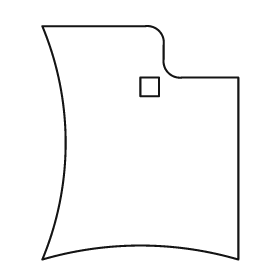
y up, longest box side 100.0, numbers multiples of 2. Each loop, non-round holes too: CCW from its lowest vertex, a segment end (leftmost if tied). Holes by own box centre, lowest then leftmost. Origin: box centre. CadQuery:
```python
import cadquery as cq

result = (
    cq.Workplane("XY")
    .moveTo(-42.0, -50.0)
    .threePointArc((0.0, -44.0), (42.0, -50.0))
    .lineTo(42.0, 28.0)
    .lineTo(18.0, 28.0)
    .threePointArc((12.0, 30.0), (10.0, 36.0))
    .lineTo(10.0, 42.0)
    .threePointArc((8.0, 48.0), (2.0, 50.0))
    .lineTo(-42.0, 50.0)
    .threePointArc((-32.0, 0.0), (-42.0, -50.0))
    .close()
    .moveTo(0.0, 20.0)
    .lineTo(8.0, 20.0)
    .lineTo(8.0, 28.0)
    .lineTo(0.0, 28.0)
    .close()
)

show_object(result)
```